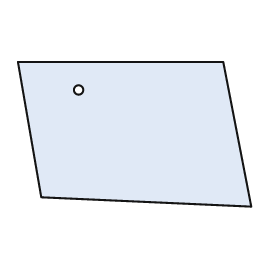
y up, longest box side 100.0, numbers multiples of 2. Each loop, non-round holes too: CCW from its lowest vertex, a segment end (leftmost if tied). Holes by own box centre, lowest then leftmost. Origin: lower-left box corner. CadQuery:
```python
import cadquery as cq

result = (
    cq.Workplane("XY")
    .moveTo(100.0, 0.0)
    .lineTo(88.0, 62.0)
    .lineTo(0.0, 62.0)
    .lineTo(10.0, 4.0)
    .close()
    .moveTo(26.0, 50.0)
    .circle(2.0)
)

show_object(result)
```